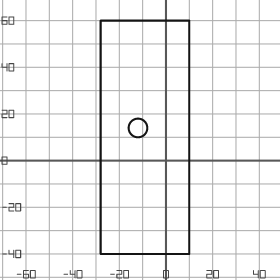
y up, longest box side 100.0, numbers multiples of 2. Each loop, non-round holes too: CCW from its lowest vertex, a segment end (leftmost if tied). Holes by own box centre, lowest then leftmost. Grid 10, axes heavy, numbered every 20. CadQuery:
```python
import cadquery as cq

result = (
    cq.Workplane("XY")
    .moveTo(-28.0, -40.0)
    .lineTo(10.0, -40.0)
    .lineTo(10.0, 60.0)
    .lineTo(-28.0, 60.0)
    .close()
    .moveTo(-12.0, 14.0)
    .circle(4.0)
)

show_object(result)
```